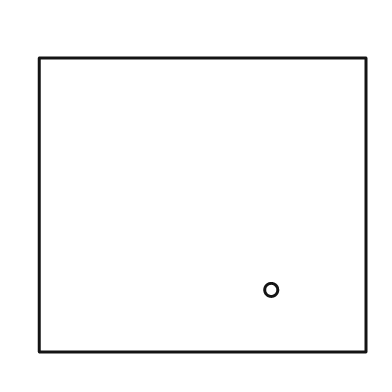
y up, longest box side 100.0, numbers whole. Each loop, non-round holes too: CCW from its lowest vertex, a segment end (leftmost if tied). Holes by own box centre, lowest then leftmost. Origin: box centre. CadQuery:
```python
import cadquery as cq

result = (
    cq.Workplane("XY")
    .moveTo(-50.0, -45.0)
    .lineTo(50.0, -45.0)
    .lineTo(50.0, 45.0)
    .lineTo(-50.0, 45.0)
    .close()
    .moveTo(21.0, -26.0)
    .circle(2.0)
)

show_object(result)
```